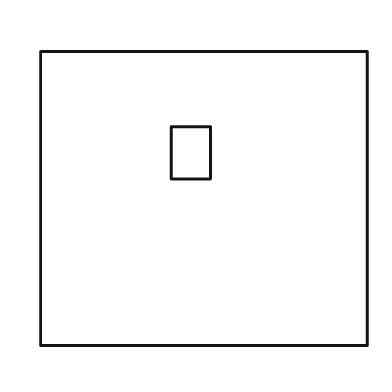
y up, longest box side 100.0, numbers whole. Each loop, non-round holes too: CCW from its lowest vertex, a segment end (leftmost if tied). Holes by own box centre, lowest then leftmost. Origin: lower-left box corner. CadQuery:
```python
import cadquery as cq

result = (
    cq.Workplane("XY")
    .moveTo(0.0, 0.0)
    .lineTo(100.0, 0.0)
    .lineTo(100.0, 90.0)
    .lineTo(0.0, 90.0)
    .close()
    .moveTo(40.0, 51.0)
    .lineTo(52.0, 51.0)
    .lineTo(52.0, 67.0)
    .lineTo(40.0, 67.0)
    .close()
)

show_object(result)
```